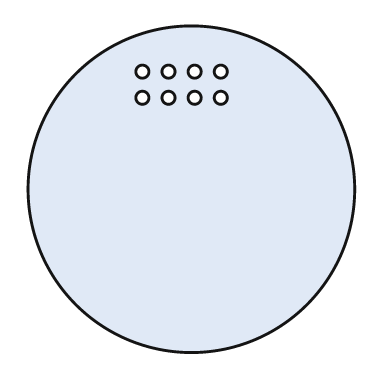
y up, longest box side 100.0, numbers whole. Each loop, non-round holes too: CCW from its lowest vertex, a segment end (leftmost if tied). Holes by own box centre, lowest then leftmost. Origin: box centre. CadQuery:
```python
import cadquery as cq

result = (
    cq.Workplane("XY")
    .moveTo(0.0, 0.0)
    .circle(50.0)
    .moveTo(-15.0, 28.0)
    .circle(2.0)
    .moveTo(-7.0, 28.0)
    .circle(2.0)
    .moveTo(1.0, 28.0)
    .circle(2.0)
    .moveTo(9.0, 28.0)
    .circle(2.0)
    .moveTo(-15.0, 36.0)
    .circle(2.0)
    .moveTo(-7.0, 36.0)
    .circle(2.0)
    .moveTo(1.0, 36.0)
    .circle(2.0)
    .moveTo(9.0, 36.0)
    .circle(2.0)
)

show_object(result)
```